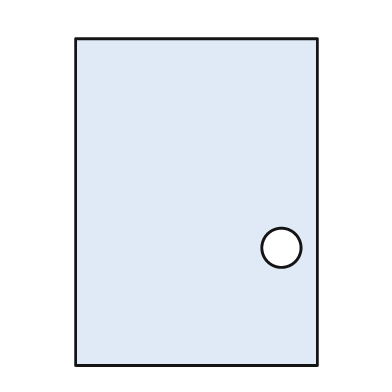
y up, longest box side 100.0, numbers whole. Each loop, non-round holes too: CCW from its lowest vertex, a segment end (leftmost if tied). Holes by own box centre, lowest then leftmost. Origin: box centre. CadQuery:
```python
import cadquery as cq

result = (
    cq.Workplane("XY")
    .moveTo(-37.0, -50.0)
    .lineTo(37.0, -50.0)
    .lineTo(37.0, 50.0)
    .lineTo(-37.0, 50.0)
    .close()
    .moveTo(26.0, -14.0)
    .circle(6.0)
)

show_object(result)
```